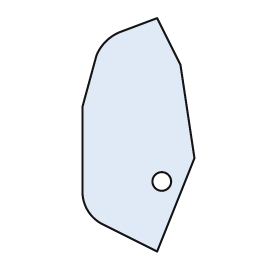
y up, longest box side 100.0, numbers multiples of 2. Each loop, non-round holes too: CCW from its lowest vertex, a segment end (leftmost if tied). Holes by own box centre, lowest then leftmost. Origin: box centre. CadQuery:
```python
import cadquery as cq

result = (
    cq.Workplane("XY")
    .moveTo(8.0, -50.0)
    .lineTo(24.0, -10.0)
    .lineTo(18.0, 30.0)
    .lineTo(8.0, 50.0)
    .lineTo(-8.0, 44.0)
    .threePointArc((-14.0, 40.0), (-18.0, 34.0))
    .lineTo(-24.0, 12.0)
    .lineTo(-24.0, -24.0)
    .threePointArc((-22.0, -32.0), (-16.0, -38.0))
    .close()
    .moveTo(10.0, -20.0)
    .circle(4.0)
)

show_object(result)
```